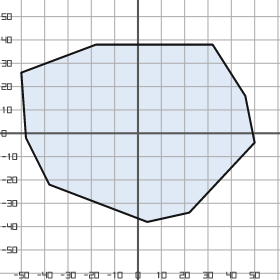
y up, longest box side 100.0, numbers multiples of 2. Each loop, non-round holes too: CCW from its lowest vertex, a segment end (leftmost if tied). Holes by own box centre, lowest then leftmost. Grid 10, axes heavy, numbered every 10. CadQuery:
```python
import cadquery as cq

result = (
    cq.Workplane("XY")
    .moveTo(4.0, -38.0)
    .lineTo(22.0, -34.0)
    .lineTo(50.0, -4.0)
    .lineTo(46.0, 16.0)
    .lineTo(32.0, 38.0)
    .lineTo(-18.0, 38.0)
    .lineTo(-50.0, 26.0)
    .lineTo(-48.0, -2.0)
    .lineTo(-38.0, -22.0)
    .close()
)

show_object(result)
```